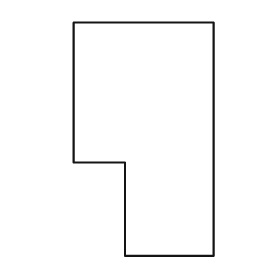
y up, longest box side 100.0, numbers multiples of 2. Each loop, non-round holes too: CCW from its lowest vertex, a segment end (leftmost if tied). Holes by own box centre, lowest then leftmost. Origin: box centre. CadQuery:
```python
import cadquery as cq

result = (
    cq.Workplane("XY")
    .moveTo(-8.0, -50.0)
    .lineTo(30.0, -50.0)
    .lineTo(30.0, 50.0)
    .lineTo(-30.0, 50.0)
    .lineTo(-30.0, -10.0)
    .lineTo(-8.0, -10.0)
    .close()
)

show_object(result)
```